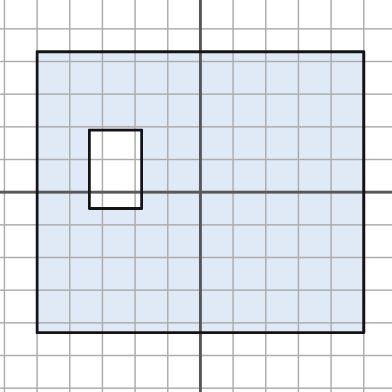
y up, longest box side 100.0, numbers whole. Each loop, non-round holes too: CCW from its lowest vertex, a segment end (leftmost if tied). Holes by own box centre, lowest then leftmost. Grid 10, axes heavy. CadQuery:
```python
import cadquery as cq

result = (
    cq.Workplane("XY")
    .moveTo(-50.0, -43.0)
    .lineTo(50.0, -43.0)
    .lineTo(50.0, 43.0)
    .lineTo(-50.0, 43.0)
    .close()
    .moveTo(-34.0, -5.0)
    .lineTo(-18.0, -5.0)
    .lineTo(-18.0, 19.0)
    .lineTo(-34.0, 19.0)
    .close()
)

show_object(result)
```